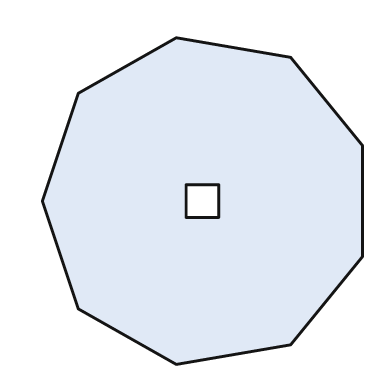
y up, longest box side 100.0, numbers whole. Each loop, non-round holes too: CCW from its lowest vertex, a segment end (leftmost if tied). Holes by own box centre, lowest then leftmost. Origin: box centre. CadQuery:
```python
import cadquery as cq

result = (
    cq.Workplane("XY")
    .moveTo(-8.0, -50.0)
    .lineTo(27.0, -44.0)
    .lineTo(49.0, -17.0)
    .lineTo(49.0, 17.0)
    .lineTo(27.0, 44.0)
    .lineTo(-8.0, 50.0)
    .lineTo(-38.0, 33.0)
    .lineTo(-49.0, 0.0)
    .lineTo(-38.0, -33.0)
    .close()
    .moveTo(-5.0, -5.0)
    .lineTo(5.0, -5.0)
    .lineTo(5.0, 5.0)
    .lineTo(-5.0, 5.0)
    .close()
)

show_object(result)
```